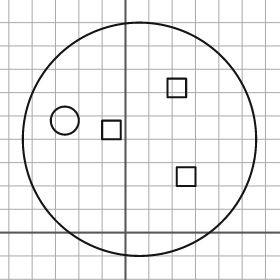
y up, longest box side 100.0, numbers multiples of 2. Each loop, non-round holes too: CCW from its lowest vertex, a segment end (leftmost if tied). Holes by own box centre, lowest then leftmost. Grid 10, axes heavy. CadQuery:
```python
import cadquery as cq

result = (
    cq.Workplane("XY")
    .moveTo(6.0, 40.0)
    .circle(50.0)
    .moveTo(22.0, 20.0)
    .lineTo(30.0, 20.0)
    .lineTo(30.0, 28.0)
    .lineTo(22.0, 28.0)
    .close()
    .moveTo(-10.0, 40.0)
    .lineTo(-2.0, 40.0)
    .lineTo(-2.0, 48.0)
    .lineTo(-10.0, 48.0)
    .close()
    .moveTo(-26.0, 48.0)
    .circle(6.0)
    .moveTo(18.0, 58.0)
    .lineTo(26.0, 58.0)
    .lineTo(26.0, 66.0)
    .lineTo(18.0, 66.0)
    .close()
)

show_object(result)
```